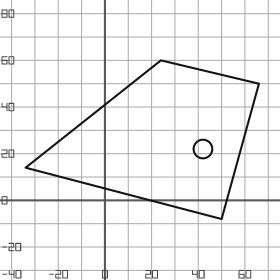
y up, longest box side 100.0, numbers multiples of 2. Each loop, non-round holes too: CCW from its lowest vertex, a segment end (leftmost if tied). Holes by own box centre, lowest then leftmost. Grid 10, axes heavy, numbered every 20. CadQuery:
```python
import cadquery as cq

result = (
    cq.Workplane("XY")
    .moveTo(50.0, -8.0)
    .lineTo(66.0, 50.0)
    .lineTo(24.0, 60.0)
    .lineTo(-34.0, 14.0)
    .close()
    .moveTo(42.0, 22.0)
    .circle(4.0)
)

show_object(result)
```